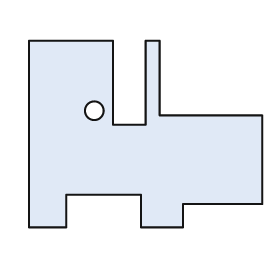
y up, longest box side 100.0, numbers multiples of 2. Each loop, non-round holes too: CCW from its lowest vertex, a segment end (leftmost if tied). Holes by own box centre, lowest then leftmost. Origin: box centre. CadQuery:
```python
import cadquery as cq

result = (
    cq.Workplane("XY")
    .moveTo(-50.0, -40.0)
    .lineTo(-34.0, -40.0)
    .lineTo(-34.0, -26.0)
    .lineTo(-2.0, -26.0)
    .lineTo(-2.0, -40.0)
    .lineTo(16.0, -40.0)
    .lineTo(16.0, -30.0)
    .lineTo(50.0, -30.0)
    .lineTo(50.0, 8.0)
    .lineTo(6.0, 8.0)
    .lineTo(6.0, 40.0)
    .lineTo(0.0, 40.0)
    .lineTo(0.0, 4.0)
    .lineTo(-14.0, 4.0)
    .lineTo(-14.0, 40.0)
    .lineTo(-50.0, 40.0)
    .close()
    .moveTo(-22.0, 10.0)
    .circle(4.0)
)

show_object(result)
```